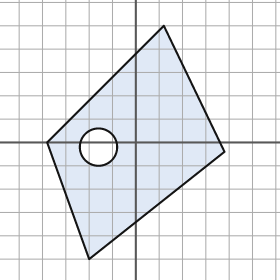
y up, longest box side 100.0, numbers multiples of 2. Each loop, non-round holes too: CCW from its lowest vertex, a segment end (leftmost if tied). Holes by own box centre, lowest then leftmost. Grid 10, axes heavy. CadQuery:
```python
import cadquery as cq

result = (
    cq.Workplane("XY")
    .moveTo(-20.0, -50.0)
    .lineTo(38.0, -4.0)
    .lineTo(12.0, 50.0)
    .lineTo(-38.0, 0.0)
    .close()
    .moveTo(-16.0, -2.0)
    .circle(8.0)
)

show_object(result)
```